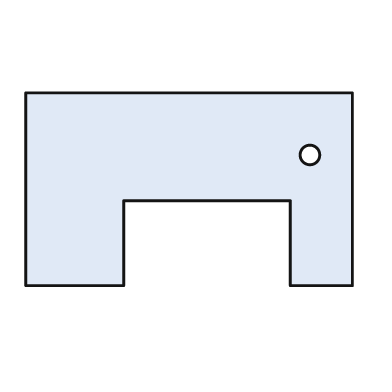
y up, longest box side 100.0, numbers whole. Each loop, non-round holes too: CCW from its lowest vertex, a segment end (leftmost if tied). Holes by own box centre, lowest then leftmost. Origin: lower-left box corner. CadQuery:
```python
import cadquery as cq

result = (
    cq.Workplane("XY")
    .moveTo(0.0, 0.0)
    .lineTo(30.0, 0.0)
    .lineTo(30.0, 26.0)
    .lineTo(81.0, 26.0)
    .lineTo(81.0, 0.0)
    .lineTo(100.0, 0.0)
    .lineTo(100.0, 59.0)
    .lineTo(0.0, 59.0)
    .close()
    .moveTo(87.0, 40.0)
    .circle(3.0)
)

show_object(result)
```